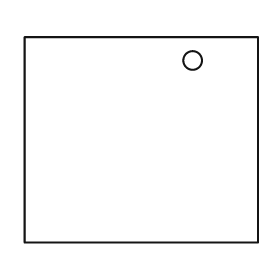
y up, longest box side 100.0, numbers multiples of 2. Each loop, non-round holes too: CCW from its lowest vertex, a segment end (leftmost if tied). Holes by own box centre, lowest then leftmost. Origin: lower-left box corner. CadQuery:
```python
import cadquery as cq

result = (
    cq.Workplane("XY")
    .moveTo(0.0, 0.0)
    .lineTo(100.0, 0.0)
    .lineTo(100.0, 88.0)
    .lineTo(0.0, 88.0)
    .close()
    .moveTo(72.0, 78.0)
    .circle(4.0)
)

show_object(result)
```